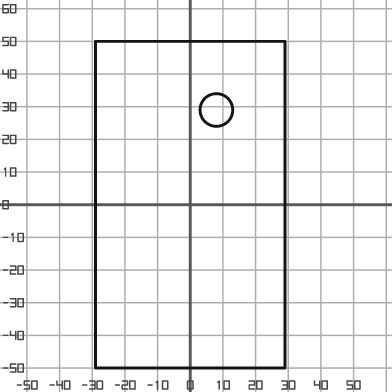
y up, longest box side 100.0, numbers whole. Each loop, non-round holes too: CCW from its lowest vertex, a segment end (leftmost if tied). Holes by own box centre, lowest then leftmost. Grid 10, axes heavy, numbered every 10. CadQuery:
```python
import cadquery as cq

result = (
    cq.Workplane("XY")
    .moveTo(-29.0, -50.0)
    .lineTo(29.0, -50.0)
    .lineTo(29.0, 50.0)
    .lineTo(-29.0, 50.0)
    .close()
    .moveTo(8.0, 29.0)
    .circle(5.0)
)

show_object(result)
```